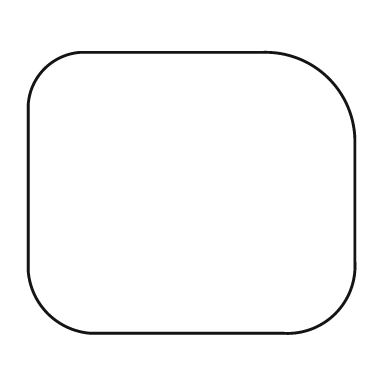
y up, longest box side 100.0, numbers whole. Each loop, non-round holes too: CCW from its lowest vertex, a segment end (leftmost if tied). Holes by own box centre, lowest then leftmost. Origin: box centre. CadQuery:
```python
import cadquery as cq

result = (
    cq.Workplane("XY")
    .moveTo(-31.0, -43.0)
    .lineTo(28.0, -43.0)
    .threePointArc((44.0, -37.0), (50.0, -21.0))
    .lineTo(50.0, 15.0)
    .threePointArc((42.0, 35.0), (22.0, 43.0))
    .lineTo(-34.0, 43.0)
    .threePointArc((-45.0, 38.0), (-50.0, 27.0))
    .lineTo(-50.0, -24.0)
    .threePointArc((-44.0, -37.0), (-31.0, -43.0))
    .close()
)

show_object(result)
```